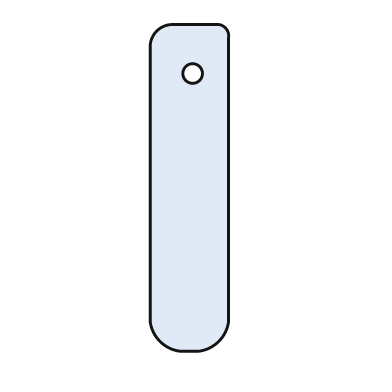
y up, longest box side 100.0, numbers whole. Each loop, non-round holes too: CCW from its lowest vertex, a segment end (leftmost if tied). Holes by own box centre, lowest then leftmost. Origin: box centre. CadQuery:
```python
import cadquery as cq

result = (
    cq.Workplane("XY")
    .moveTo(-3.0, -50.0)
    .lineTo(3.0, -50.0)
    .threePointArc((9.0, -47.0), (12.0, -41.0))
    .lineTo(12.0, 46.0)
    .threePointArc((11.0, 49.0), (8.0, 50.0))
    .lineTo(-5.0, 50.0)
    .threePointArc((-10.0, 48.0), (-12.0, 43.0))
    .lineTo(-12.0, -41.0)
    .threePointArc((-9.0, -47.0), (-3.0, -50.0))
    .close()
    .moveTo(1.0, 35.0)
    .circle(3.0)
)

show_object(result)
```